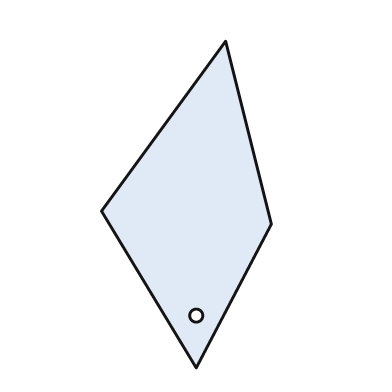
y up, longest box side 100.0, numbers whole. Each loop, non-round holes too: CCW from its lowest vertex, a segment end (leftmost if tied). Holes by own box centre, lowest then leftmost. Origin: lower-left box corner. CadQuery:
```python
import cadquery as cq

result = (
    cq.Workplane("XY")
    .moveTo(29.0, 0.0)
    .lineTo(52.0, 44.0)
    .lineTo(38.0, 100.0)
    .lineTo(0.0, 48.0)
    .close()
    .moveTo(29.0, 16.0)
    .circle(2.0)
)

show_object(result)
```